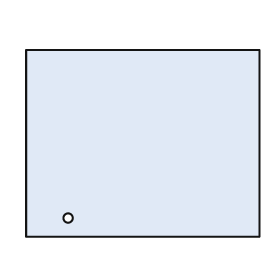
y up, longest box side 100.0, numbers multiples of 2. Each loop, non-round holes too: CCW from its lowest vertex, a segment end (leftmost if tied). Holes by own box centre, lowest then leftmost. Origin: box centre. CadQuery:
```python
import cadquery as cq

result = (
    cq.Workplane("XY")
    .moveTo(-50.0, -40.0)
    .lineTo(50.0, -40.0)
    .lineTo(50.0, 40.0)
    .lineTo(-50.0, 40.0)
    .close()
    .moveTo(-32.0, -32.0)
    .circle(2.0)
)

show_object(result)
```